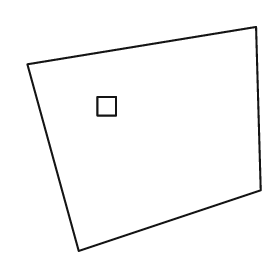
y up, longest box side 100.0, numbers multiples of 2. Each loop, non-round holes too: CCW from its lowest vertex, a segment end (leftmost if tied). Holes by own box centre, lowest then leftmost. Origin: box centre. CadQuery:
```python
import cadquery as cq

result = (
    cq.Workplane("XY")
    .moveTo(-28.0, -48.0)
    .lineTo(50.0, -22.0)
    .lineTo(48.0, 48.0)
    .lineTo(-50.0, 32.0)
    .close()
    .moveTo(-20.0, 10.0)
    .lineTo(-12.0, 10.0)
    .lineTo(-12.0, 18.0)
    .lineTo(-20.0, 18.0)
    .close()
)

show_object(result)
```